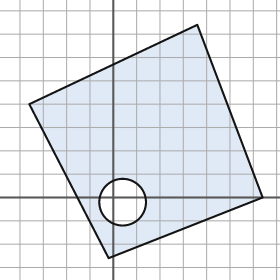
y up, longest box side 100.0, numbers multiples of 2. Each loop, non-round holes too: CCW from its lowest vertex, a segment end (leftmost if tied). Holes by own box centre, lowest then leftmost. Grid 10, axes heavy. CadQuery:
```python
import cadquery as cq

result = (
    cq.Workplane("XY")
    .moveTo(-2.0, -26.0)
    .lineTo(64.0, 0.0)
    .lineTo(36.0, 74.0)
    .lineTo(-36.0, 40.0)
    .close()
    .moveTo(4.0, -2.0)
    .circle(10.0)
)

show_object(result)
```